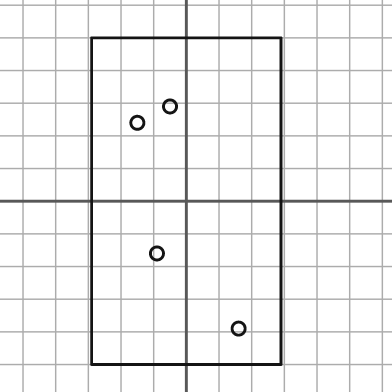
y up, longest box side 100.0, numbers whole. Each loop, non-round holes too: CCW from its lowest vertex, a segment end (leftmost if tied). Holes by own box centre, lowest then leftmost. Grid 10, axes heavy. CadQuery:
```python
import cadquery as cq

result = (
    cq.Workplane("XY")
    .moveTo(-29.0, -50.0)
    .lineTo(29.0, -50.0)
    .lineTo(29.0, 50.0)
    .lineTo(-29.0, 50.0)
    .close()
    .moveTo(16.0, -39.0)
    .circle(2.0)
    .moveTo(-9.0, -16.0)
    .circle(2.0)
    .moveTo(-15.0, 24.0)
    .circle(2.0)
    .moveTo(-5.0, 29.0)
    .circle(2.0)
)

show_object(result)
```